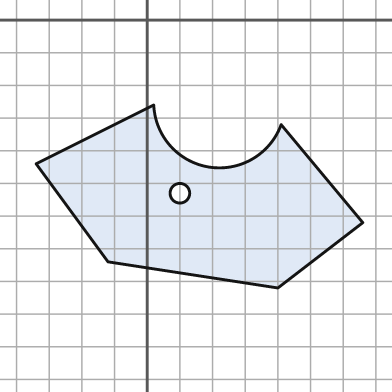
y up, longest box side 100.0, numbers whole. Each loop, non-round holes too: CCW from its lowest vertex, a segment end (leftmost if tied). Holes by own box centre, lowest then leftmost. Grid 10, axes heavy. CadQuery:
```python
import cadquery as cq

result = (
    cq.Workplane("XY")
    .moveTo(40.0, -82.0)
    .lineTo(66.0, -62.0)
    .lineTo(41.0, -32.0)
    .threePointArc((19.0, -45.0), (2.0, -26.0))
    .lineTo(-34.0, -44.0)
    .lineTo(-12.0, -74.0)
    .close()
    .moveTo(10.0, -53.0)
    .circle(3.0)
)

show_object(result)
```